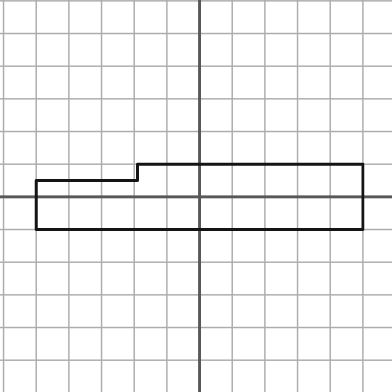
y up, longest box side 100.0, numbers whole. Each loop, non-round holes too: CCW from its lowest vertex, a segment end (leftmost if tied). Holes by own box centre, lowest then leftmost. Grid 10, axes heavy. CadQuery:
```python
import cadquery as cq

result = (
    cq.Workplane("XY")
    .moveTo(-50.0, -10.0)
    .lineTo(50.0, -10.0)
    .lineTo(50.0, 10.0)
    .lineTo(-19.0, 10.0)
    .lineTo(-19.0, 5.0)
    .lineTo(-50.0, 5.0)
    .close()
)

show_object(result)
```